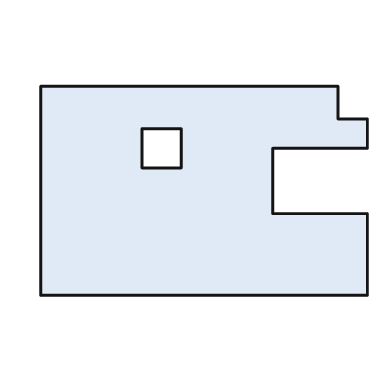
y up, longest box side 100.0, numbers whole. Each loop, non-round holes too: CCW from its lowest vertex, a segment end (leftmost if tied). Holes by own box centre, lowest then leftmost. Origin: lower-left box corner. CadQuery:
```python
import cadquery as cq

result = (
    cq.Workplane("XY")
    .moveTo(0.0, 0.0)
    .lineTo(100.0, 0.0)
    .lineTo(100.0, 25.0)
    .lineTo(71.0, 25.0)
    .lineTo(71.0, 45.0)
    .lineTo(100.0, 45.0)
    .lineTo(100.0, 54.0)
    .lineTo(91.0, 54.0)
    .lineTo(91.0, 64.0)
    .lineTo(0.0, 64.0)
    .close()
    .moveTo(31.0, 39.0)
    .lineTo(43.0, 39.0)
    .lineTo(43.0, 51.0)
    .lineTo(31.0, 51.0)
    .close()
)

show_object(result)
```